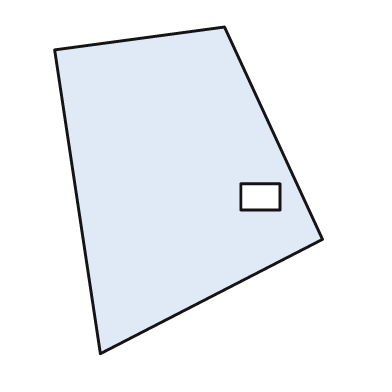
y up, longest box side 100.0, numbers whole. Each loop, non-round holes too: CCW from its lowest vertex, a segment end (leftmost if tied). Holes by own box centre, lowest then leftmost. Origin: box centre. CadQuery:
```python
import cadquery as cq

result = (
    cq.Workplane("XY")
    .moveTo(-27.0, -50.0)
    .lineTo(41.0, -15.0)
    .lineTo(11.0, 50.0)
    .lineTo(-41.0, 43.0)
    .close()
    .moveTo(16.0, -6.0)
    .lineTo(28.0, -6.0)
    .lineTo(28.0, 2.0)
    .lineTo(16.0, 2.0)
    .close()
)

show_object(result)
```